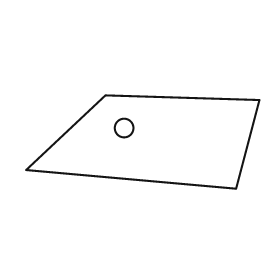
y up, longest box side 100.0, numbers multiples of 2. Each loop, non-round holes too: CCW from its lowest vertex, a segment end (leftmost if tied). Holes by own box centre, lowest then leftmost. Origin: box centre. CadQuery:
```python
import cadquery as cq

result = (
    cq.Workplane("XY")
    .moveTo(40.0, -20.0)
    .lineTo(50.0, 18.0)
    .lineTo(-16.0, 20.0)
    .lineTo(-50.0, -12.0)
    .close()
    .moveTo(-8.0, 6.0)
    .circle(4.0)
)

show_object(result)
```